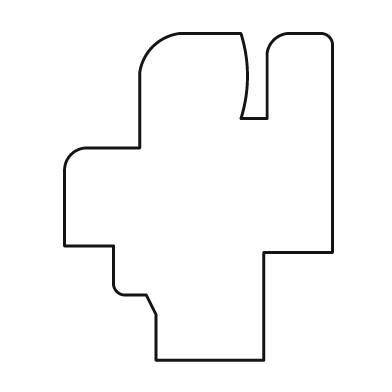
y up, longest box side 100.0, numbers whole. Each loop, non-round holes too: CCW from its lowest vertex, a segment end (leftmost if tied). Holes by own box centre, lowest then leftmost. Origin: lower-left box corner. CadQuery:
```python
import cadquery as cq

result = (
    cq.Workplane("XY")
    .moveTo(28.0, 0.0)
    .lineTo(61.0, 0.0)
    .lineTo(61.0, 33.0)
    .lineTo(82.0, 33.0)
    .lineTo(82.0, 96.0)
    .threePointArc((81.0, 99.0), (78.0, 100.0))
    .lineTo(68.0, 100.0)
    .threePointArc((64.0, 98.0), (62.0, 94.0))
    .lineTo(62.0, 74.0)
    .lineTo(54.0, 74.0)
    .threePointArc((56.0, 87.0), (54.0, 100.0))
    .lineTo(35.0, 100.0)
    .threePointArc((27.0, 96.0), (23.0, 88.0))
    .lineTo(23.0, 65.0)
    .lineTo(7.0, 65.0)
    .threePointArc((2.0, 63.0), (0.0, 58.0))
    .lineTo(0.0, 35.0)
    .lineTo(15.0, 35.0)
    .lineTo(15.0, 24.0)
    .threePointArc((16.0, 21.0), (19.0, 20.0))
    .lineTo(25.0, 20.0)
    .lineTo(28.0, 14.0)
    .close()
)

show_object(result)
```